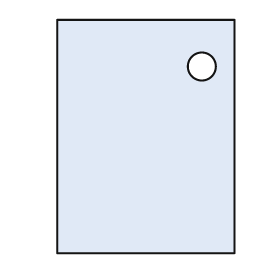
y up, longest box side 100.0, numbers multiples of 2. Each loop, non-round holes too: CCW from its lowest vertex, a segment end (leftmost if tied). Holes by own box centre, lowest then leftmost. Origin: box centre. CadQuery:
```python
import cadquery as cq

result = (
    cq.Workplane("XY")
    .moveTo(-38.0, -50.0)
    .lineTo(38.0, -50.0)
    .lineTo(38.0, 50.0)
    .lineTo(-38.0, 50.0)
    .close()
    .moveTo(24.0, 30.0)
    .circle(6.0)
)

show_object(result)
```